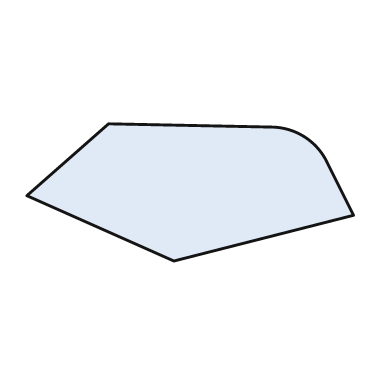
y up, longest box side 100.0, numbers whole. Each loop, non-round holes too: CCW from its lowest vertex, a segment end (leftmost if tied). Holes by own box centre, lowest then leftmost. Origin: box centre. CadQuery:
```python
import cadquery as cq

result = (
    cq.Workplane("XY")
    .moveTo(-5.0, -21.0)
    .lineTo(50.0, -7.0)
    .lineTo(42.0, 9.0)
    .threePointArc((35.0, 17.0), (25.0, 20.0))
    .lineTo(-25.0, 21.0)
    .lineTo(-50.0, -1.0)
    .close()
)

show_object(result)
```